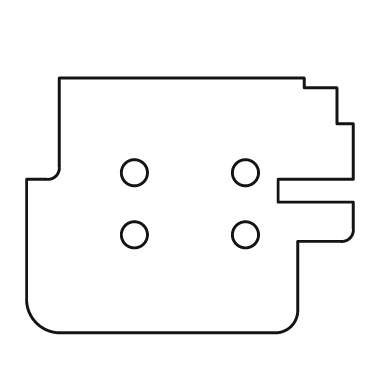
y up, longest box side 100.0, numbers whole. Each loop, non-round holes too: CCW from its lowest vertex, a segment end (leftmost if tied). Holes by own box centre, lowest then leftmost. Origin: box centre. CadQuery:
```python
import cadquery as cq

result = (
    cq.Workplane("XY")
    .moveTo(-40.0, -39.0)
    .lineTo(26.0, -39.0)
    .threePointArc((31.0, -37.0), (33.0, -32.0))
    .lineTo(33.0, -11.0)
    .lineTo(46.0, -11.0)
    .threePointArc((49.0, -10.0), (50.0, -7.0))
    .lineTo(50.0, 1.0)
    .lineTo(27.0, 1.0)
    .lineTo(27.0, 8.0)
    .lineTo(50.0, 8.0)
    .lineTo(50.0, 25.0)
    .lineTo(45.0, 25.0)
    .lineTo(45.0, 36.0)
    .lineTo(35.0, 36.0)
    .lineTo(35.0, 39.0)
    .lineTo(-40.0, 39.0)
    .lineTo(-40.0, 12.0)
    .threePointArc((-41.0, 9.0), (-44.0, 8.0))
    .lineTo(-50.0, 8.0)
    .lineTo(-50.0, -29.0)
    .threePointArc((-47.0, -36.0), (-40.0, -39.0))
    .close()
    .moveTo(-17.0, -9.0)
    .circle(4.0)
    .moveTo(17.0, -9.0)
    .circle(4.0)
    .moveTo(-17.0, 10.0)
    .circle(4.0)
    .moveTo(17.0, 10.0)
    .circle(4.0)
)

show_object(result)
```